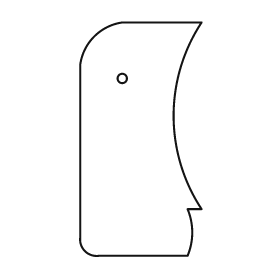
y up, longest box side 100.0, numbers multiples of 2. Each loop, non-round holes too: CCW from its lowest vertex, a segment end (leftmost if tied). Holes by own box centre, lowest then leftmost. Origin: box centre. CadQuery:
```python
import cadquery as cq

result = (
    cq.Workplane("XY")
    .moveTo(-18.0, -50.0)
    .lineTo(20.0, -50.0)
    .threePointArc((22.0, -40.0), (20.0, -30.0))
    .lineTo(26.0, -30.0)
    .threePointArc((14.0, 10.0), (26.0, 50.0))
    .lineTo(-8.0, 50.0)
    .threePointArc((-20.0, 44.0), (-26.0, 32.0))
    .lineTo(-26.0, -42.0)
    .threePointArc((-24.0, -48.0), (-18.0, -50.0))
    .close()
    .moveTo(-8.0, 26.0)
    .circle(2.0)
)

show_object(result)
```